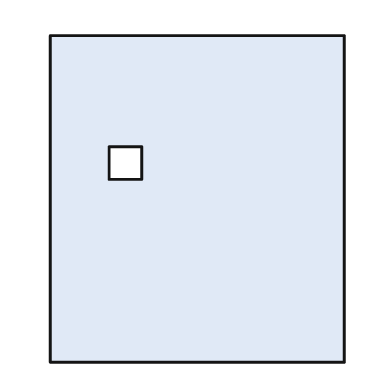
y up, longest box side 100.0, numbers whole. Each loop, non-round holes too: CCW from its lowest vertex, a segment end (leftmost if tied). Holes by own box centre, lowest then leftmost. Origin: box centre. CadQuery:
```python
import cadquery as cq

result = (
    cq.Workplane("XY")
    .moveTo(-45.0, -50.0)
    .lineTo(45.0, -50.0)
    .lineTo(45.0, 50.0)
    .lineTo(-45.0, 50.0)
    .close()
    .moveTo(-27.0, 6.0)
    .lineTo(-17.0, 6.0)
    .lineTo(-17.0, 16.0)
    .lineTo(-27.0, 16.0)
    .close()
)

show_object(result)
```